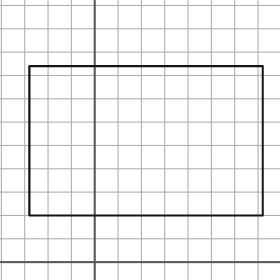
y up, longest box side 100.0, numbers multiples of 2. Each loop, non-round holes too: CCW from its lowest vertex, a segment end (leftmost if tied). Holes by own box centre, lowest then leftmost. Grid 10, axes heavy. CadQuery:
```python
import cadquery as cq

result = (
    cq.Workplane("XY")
    .moveTo(-28.0, 20.0)
    .lineTo(72.0, 20.0)
    .lineTo(72.0, 84.0)
    .lineTo(-28.0, 84.0)
    .close()
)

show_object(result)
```